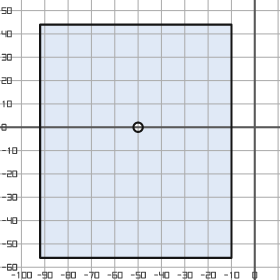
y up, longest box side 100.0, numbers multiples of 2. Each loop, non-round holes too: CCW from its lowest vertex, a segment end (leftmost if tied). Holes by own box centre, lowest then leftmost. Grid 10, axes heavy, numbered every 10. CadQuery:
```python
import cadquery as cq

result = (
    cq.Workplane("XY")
    .moveTo(-92.0, -56.0)
    .lineTo(-10.0, -56.0)
    .lineTo(-10.0, 44.0)
    .lineTo(-92.0, 44.0)
    .close()
    .moveTo(-50.0, 0.0)
    .circle(2.0)
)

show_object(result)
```